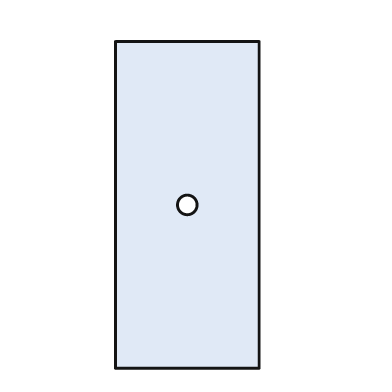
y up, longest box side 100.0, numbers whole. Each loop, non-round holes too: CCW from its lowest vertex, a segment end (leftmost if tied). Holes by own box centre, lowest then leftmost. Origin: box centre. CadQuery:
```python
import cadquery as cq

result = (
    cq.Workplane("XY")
    .moveTo(-22.0, -50.0)
    .lineTo(22.0, -50.0)
    .lineTo(22.0, 50.0)
    .lineTo(-22.0, 50.0)
    .close()
    .moveTo(0.0, 0.0)
    .circle(3.0)
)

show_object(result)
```